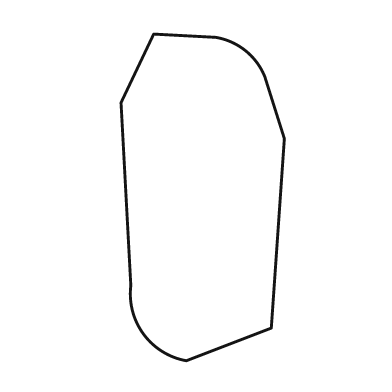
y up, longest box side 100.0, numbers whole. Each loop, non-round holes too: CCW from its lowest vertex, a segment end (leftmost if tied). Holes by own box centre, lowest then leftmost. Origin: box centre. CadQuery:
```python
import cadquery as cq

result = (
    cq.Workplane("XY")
    .moveTo(-5.0, -50.0)
    .lineTo(21.0, -40.0)
    .lineTo(25.0, 18.0)
    .lineTo(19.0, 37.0)
    .threePointArc((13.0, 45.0), (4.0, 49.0))
    .lineTo(-15.0, 50.0)
    .lineTo(-25.0, 29.0)
    .lineTo(-22.0, -27.0)
    .threePointArc((-18.0, -42.0), (-5.0, -50.0))
    .close()
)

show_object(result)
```